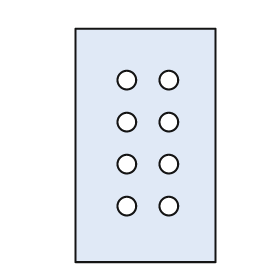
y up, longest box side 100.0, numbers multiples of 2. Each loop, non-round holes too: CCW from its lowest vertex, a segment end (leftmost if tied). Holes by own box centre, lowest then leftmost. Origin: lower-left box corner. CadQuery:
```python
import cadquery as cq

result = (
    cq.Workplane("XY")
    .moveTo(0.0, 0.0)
    .lineTo(60.0, 0.0)
    .lineTo(60.0, 100.0)
    .lineTo(0.0, 100.0)
    .close()
    .moveTo(22.0, 24.0)
    .circle(4.0)
    .moveTo(40.0, 24.0)
    .circle(4.0)
    .moveTo(22.0, 42.0)
    .circle(4.0)
    .moveTo(40.0, 42.0)
    .circle(4.0)
    .moveTo(22.0, 60.0)
    .circle(4.0)
    .moveTo(40.0, 60.0)
    .circle(4.0)
    .moveTo(22.0, 78.0)
    .circle(4.0)
    .moveTo(40.0, 78.0)
    .circle(4.0)
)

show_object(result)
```